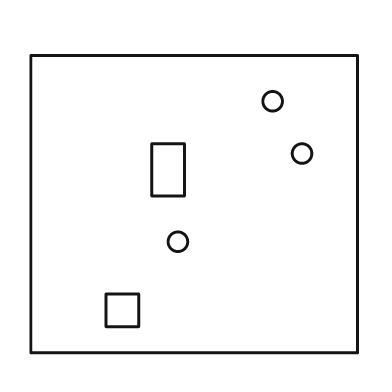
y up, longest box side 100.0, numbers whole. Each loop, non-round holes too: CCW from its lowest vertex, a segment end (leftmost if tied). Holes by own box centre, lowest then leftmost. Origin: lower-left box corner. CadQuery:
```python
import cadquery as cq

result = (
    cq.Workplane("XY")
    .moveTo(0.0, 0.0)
    .lineTo(100.0, 0.0)
    .lineTo(100.0, 91.0)
    .lineTo(0.0, 91.0)
    .close()
    .moveTo(23.0, 8.0)
    .lineTo(33.0, 8.0)
    .lineTo(33.0, 18.0)
    .lineTo(23.0, 18.0)
    .close()
    .moveTo(45.0, 34.0)
    .circle(3.0)
    .moveTo(37.0, 48.0)
    .lineTo(47.0, 48.0)
    .lineTo(47.0, 64.0)
    .lineTo(37.0, 64.0)
    .close()
    .moveTo(83.0, 61.0)
    .circle(3.0)
    .moveTo(74.0, 77.0)
    .circle(3.0)
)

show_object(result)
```